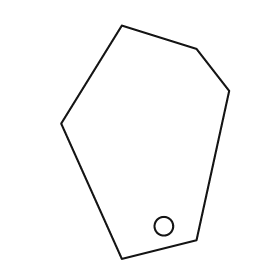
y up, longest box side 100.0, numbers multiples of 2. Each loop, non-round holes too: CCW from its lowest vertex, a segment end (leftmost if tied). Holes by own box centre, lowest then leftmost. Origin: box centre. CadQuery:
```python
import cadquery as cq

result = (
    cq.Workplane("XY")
    .moveTo(-10.0, -50.0)
    .lineTo(22.0, -42.0)
    .lineTo(36.0, 22.0)
    .lineTo(22.0, 40.0)
    .lineTo(-10.0, 50.0)
    .lineTo(-36.0, 8.0)
    .close()
    .moveTo(8.0, -36.0)
    .circle(4.0)
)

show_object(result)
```